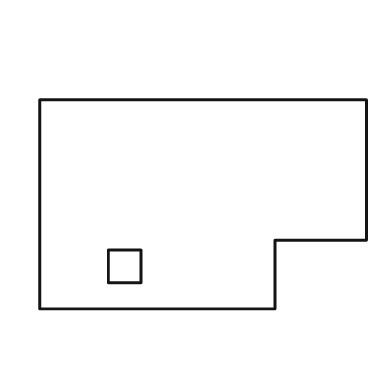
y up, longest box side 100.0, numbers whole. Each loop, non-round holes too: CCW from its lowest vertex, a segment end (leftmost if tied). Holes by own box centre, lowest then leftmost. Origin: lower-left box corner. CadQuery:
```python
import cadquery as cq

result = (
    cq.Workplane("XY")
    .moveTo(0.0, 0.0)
    .lineTo(72.0, 0.0)
    .lineTo(72.0, 21.0)
    .lineTo(100.0, 21.0)
    .lineTo(100.0, 64.0)
    .lineTo(0.0, 64.0)
    .close()
    .moveTo(21.0, 8.0)
    .lineTo(31.0, 8.0)
    .lineTo(31.0, 18.0)
    .lineTo(21.0, 18.0)
    .close()
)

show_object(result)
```